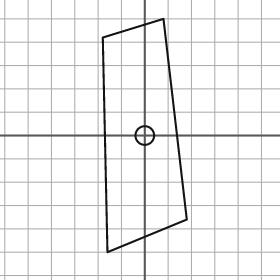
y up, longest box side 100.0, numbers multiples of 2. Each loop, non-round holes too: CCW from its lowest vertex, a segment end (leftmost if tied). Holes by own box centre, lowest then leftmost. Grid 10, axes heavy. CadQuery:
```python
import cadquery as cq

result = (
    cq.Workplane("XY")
    .moveTo(-16.0, -50.0)
    .lineTo(18.0, -36.0)
    .lineTo(8.0, 50.0)
    .lineTo(-18.0, 42.0)
    .close()
    .moveTo(0.0, 0.0)
    .circle(4.0)
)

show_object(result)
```